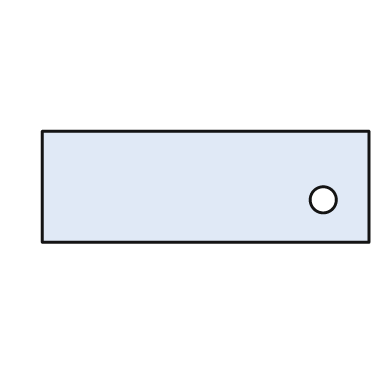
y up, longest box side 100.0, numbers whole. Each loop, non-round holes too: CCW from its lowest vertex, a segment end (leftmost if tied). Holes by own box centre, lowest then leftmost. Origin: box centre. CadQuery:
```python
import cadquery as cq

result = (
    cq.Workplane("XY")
    .moveTo(-50.0, -17.0)
    .lineTo(50.0, -17.0)
    .lineTo(50.0, 17.0)
    .lineTo(-50.0, 17.0)
    .close()
    .moveTo(36.0, -4.0)
    .circle(4.0)
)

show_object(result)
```